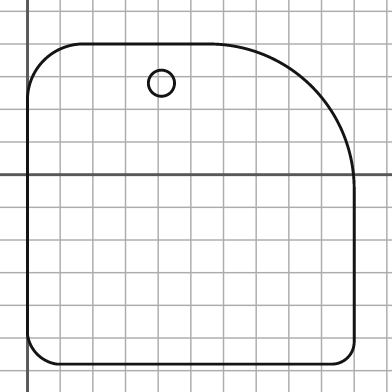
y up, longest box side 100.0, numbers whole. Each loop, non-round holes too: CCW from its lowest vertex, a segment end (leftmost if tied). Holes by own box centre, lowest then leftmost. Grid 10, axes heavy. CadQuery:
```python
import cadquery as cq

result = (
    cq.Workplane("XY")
    .moveTo(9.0, -58.0)
    .lineTo(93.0, -58.0)
    .threePointArc((98.0, -56.0), (100.0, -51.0))
    .lineTo(100.0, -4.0)
    .threePointArc((87.0, 27.0), (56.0, 40.0))
    .lineTo(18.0, 40.0)
    .threePointArc((5.0, 35.0), (0.0, 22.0))
    .lineTo(0.0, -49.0)
    .threePointArc((3.0, -55.0), (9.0, -58.0))
    .close()
    .moveTo(41.0, 28.0)
    .circle(4.0)
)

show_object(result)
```